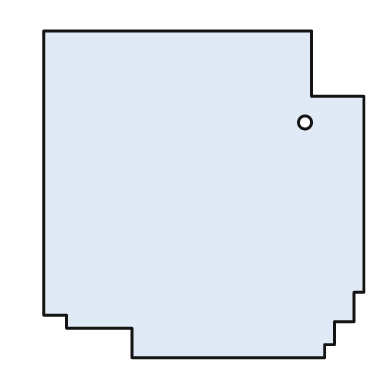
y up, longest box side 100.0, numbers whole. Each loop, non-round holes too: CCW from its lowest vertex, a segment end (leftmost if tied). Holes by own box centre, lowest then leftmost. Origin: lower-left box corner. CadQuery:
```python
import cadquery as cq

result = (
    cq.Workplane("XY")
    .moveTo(27.0, 0.0)
    .lineTo(86.0, 0.0)
    .lineTo(86.0, 4.0)
    .lineTo(89.0, 4.0)
    .lineTo(89.0, 11.0)
    .lineTo(95.0, 11.0)
    .lineTo(95.0, 20.0)
    .lineTo(98.0, 20.0)
    .lineTo(98.0, 80.0)
    .lineTo(82.0, 80.0)
    .lineTo(82.0, 100.0)
    .lineTo(0.0, 100.0)
    .lineTo(0.0, 13.0)
    .lineTo(7.0, 13.0)
    .lineTo(7.0, 9.0)
    .lineTo(27.0, 9.0)
    .close()
    .moveTo(80.0, 72.0)
    .circle(2.0)
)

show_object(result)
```